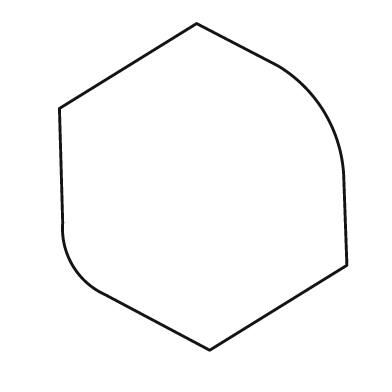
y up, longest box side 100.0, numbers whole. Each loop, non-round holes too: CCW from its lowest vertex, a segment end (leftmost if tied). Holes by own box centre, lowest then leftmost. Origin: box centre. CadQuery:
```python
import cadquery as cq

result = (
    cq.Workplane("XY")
    .moveTo(2.0, -50.0)
    .lineTo(44.0, -24.0)
    .lineTo(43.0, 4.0)
    .threePointArc((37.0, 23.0), (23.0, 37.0))
    .lineTo(-2.0, 50.0)
    .lineTo(-44.0, 24.0)
    .lineTo(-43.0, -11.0)
    .threePointArc((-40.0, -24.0), (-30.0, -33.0))
    .close()
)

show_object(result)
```